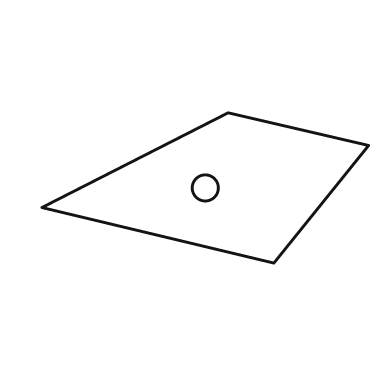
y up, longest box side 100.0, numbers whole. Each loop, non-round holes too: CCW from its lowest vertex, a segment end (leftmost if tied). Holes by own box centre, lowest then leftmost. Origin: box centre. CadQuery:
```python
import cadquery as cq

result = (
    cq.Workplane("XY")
    .moveTo(21.0, -23.0)
    .lineTo(50.0, 13.0)
    .lineTo(7.0, 23.0)
    .lineTo(-50.0, -6.0)
    .close()
    .moveTo(0.0, 0.0)
    .circle(4.0)
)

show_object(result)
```